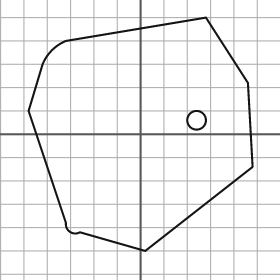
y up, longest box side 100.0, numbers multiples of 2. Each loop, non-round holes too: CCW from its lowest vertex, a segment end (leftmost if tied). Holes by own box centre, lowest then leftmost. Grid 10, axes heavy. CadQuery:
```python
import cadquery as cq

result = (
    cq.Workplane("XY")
    .moveTo(2.0, -50.0)
    .lineTo(48.0, -14.0)
    .lineTo(46.0, 22.0)
    .lineTo(28.0, 50.0)
    .lineTo(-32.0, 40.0)
    .threePointArc((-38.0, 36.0), (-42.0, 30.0))
    .lineTo(-48.0, 10.0)
    .lineTo(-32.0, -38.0)
    .threePointArc((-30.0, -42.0), (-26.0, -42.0))
    .close()
    .moveTo(24.0, 6.0)
    .circle(4.0)
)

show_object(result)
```